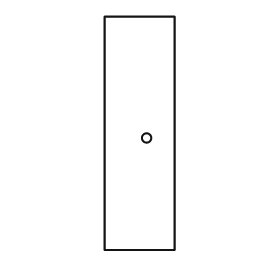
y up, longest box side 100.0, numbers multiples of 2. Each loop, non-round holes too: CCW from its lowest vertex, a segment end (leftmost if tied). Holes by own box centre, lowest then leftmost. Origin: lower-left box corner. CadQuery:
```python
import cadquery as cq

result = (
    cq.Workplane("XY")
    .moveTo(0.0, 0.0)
    .lineTo(30.0, 0.0)
    .lineTo(30.0, 100.0)
    .lineTo(0.0, 100.0)
    .close()
    .moveTo(18.0, 48.0)
    .circle(2.0)
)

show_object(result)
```